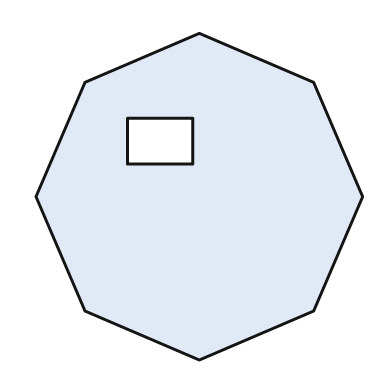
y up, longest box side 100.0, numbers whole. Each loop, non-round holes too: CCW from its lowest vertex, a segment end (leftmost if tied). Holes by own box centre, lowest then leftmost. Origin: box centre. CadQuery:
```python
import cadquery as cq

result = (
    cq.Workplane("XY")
    .moveTo(0.0, -50.0)
    .lineTo(35.0, -35.0)
    .lineTo(50.0, 0.0)
    .lineTo(35.0, 35.0)
    .lineTo(0.0, 50.0)
    .lineTo(-35.0, 35.0)
    .lineTo(-50.0, 0.0)
    .lineTo(-35.0, -35.0)
    .close()
    .moveTo(-22.0, 10.0)
    .lineTo(-2.0, 10.0)
    .lineTo(-2.0, 24.0)
    .lineTo(-22.0, 24.0)
    .close()
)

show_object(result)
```